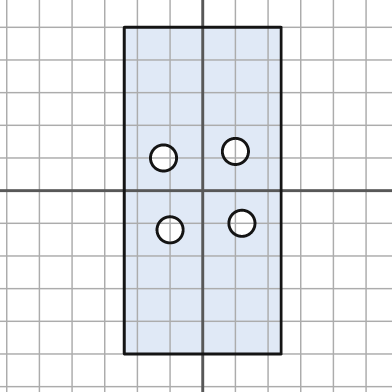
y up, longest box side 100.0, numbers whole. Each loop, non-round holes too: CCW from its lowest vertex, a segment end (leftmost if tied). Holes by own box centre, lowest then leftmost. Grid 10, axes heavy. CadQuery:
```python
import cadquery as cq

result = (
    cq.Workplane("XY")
    .moveTo(-24.0, -50.0)
    .lineTo(24.0, -50.0)
    .lineTo(24.0, 50.0)
    .lineTo(-24.0, 50.0)
    .close()
    .moveTo(-10.0, -12.0)
    .circle(4.0)
    .moveTo(12.0, -10.0)
    .circle(4.0)
    .moveTo(-12.0, 10.0)
    .circle(4.0)
    .moveTo(10.0, 12.0)
    .circle(4.0)
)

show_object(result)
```